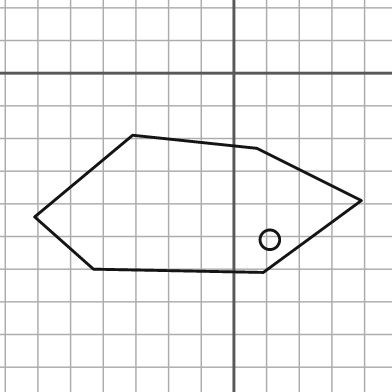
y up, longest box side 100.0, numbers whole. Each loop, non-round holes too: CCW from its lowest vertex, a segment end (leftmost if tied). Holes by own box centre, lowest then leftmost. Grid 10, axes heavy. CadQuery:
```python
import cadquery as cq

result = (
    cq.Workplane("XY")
    .moveTo(9.0, -61.0)
    .lineTo(39.0, -39.0)
    .lineTo(7.0, -23.0)
    .lineTo(-31.0, -19.0)
    .lineTo(-61.0, -44.0)
    .lineTo(-43.0, -60.0)
    .close()
    .moveTo(11.0, -51.0)
    .circle(3.0)
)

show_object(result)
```